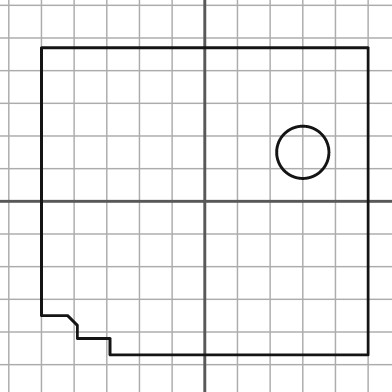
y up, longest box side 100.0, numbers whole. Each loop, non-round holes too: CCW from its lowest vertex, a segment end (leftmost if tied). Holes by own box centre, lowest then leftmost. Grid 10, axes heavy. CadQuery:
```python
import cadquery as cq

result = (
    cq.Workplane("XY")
    .moveTo(-29.0, -47.0)
    .lineTo(50.0, -47.0)
    .lineTo(50.0, 47.0)
    .lineTo(-50.0, 47.0)
    .lineTo(-50.0, -35.0)
    .lineTo(-42.0, -35.0)
    .lineTo(-39.0, -38.0)
    .lineTo(-39.0, -42.0)
    .lineTo(-29.0, -42.0)
    .close()
    .moveTo(30.0, 15.0)
    .circle(8.0)
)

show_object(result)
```